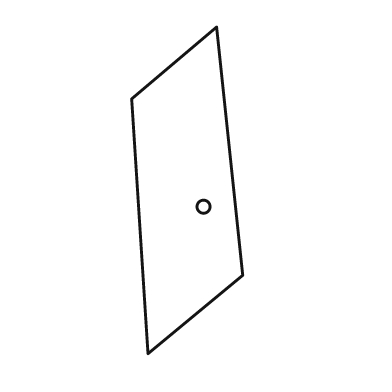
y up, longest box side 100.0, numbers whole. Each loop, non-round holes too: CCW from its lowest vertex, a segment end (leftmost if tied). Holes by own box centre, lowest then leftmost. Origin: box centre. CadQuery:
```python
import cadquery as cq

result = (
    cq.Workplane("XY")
    .moveTo(-12.0, -50.0)
    .lineTo(17.0, -26.0)
    .lineTo(9.0, 50.0)
    .lineTo(-17.0, 28.0)
    .close()
    .moveTo(5.0, -5.0)
    .circle(2.0)
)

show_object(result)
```